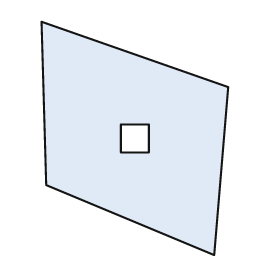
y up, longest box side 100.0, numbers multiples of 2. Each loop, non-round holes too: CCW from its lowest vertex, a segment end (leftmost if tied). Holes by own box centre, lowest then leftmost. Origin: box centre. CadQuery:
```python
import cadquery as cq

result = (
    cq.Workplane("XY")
    .moveTo(34.0, -50.0)
    .lineTo(40.0, 22.0)
    .lineTo(-40.0, 50.0)
    .lineTo(-38.0, -20.0)
    .close()
    .moveTo(-6.0, -6.0)
    .lineTo(6.0, -6.0)
    .lineTo(6.0, 6.0)
    .lineTo(-6.0, 6.0)
    .close()
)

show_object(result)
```